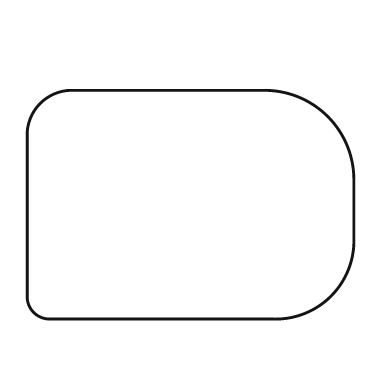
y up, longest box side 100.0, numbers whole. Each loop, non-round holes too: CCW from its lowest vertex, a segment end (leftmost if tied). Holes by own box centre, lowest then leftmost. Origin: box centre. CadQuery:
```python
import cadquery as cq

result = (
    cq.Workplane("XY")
    .moveTo(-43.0, -35.0)
    .lineTo(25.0, -35.0)
    .threePointArc((43.0, -28.0), (50.0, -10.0))
    .lineTo(50.0, 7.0)
    .threePointArc((42.0, 27.0), (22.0, 35.0))
    .lineTo(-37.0, 35.0)
    .threePointArc((-46.0, 31.0), (-50.0, 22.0))
    .lineTo(-50.0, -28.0)
    .threePointArc((-48.0, -33.0), (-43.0, -35.0))
    .close()
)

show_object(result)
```